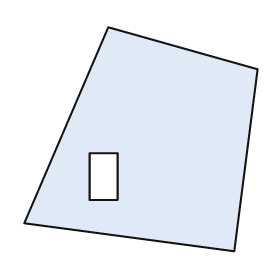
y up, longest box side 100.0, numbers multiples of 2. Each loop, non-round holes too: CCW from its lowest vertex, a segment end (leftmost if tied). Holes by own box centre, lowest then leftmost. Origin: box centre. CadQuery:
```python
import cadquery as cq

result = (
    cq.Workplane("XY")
    .moveTo(40.0, -48.0)
    .lineTo(50.0, 30.0)
    .lineTo(-14.0, 48.0)
    .lineTo(-50.0, -36.0)
    .close()
    .moveTo(-22.0, -26.0)
    .lineTo(-10.0, -26.0)
    .lineTo(-10.0, -6.0)
    .lineTo(-22.0, -6.0)
    .close()
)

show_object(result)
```